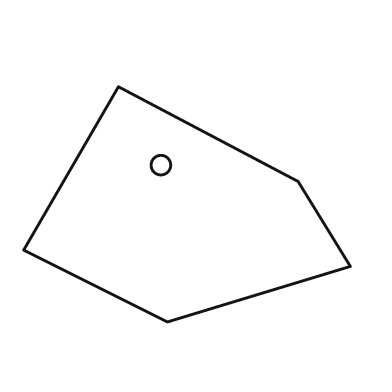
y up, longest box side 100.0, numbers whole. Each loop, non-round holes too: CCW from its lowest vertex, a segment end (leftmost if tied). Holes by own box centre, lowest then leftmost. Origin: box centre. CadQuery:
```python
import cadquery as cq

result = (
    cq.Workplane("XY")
    .moveTo(-6.0, -36.0)
    .lineTo(50.0, -19.0)
    .lineTo(34.0, 7.0)
    .lineTo(-21.0, 36.0)
    .lineTo(-50.0, -14.0)
    .close()
    .moveTo(-8.0, 12.0)
    .circle(3.0)
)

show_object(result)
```